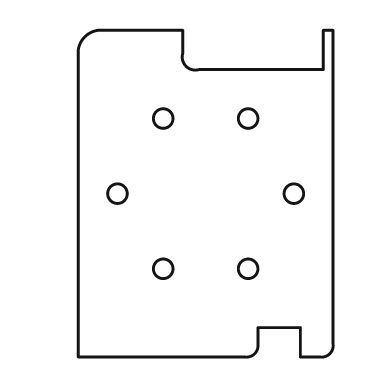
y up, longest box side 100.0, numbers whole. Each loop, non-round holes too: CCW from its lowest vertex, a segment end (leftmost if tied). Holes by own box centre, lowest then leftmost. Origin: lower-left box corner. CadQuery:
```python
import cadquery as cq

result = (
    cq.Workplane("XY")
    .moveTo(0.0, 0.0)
    .lineTo(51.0, 0.0)
    .threePointArc((54.0, 1.0), (55.0, 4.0))
    .lineTo(55.0, 9.0)
    .lineTo(68.0, 9.0)
    .lineTo(68.0, 0.0)
    .lineTo(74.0, 0.0)
    .threePointArc((77.0, 1.0), (78.0, 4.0))
    .lineTo(78.0, 100.0)
    .lineTo(75.0, 100.0)
    .lineTo(75.0, 88.0)
    .lineTo(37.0, 88.0)
    .threePointArc((33.0, 89.0), (32.0, 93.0))
    .lineTo(32.0, 100.0)
    .lineTo(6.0, 100.0)
    .threePointArc((2.0, 98.0), (0.0, 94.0))
    .close()
    .moveTo(26.0, 27.0)
    .circle(3.0)
    .moveTo(52.0, 27.0)
    .circle(3.0)
    .moveTo(12.0, 50.0)
    .circle(3.0)
    .moveTo(66.0, 50.0)
    .circle(3.0)
    .moveTo(26.0, 73.0)
    .circle(3.0)
    .moveTo(52.0, 73.0)
    .circle(3.0)
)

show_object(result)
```